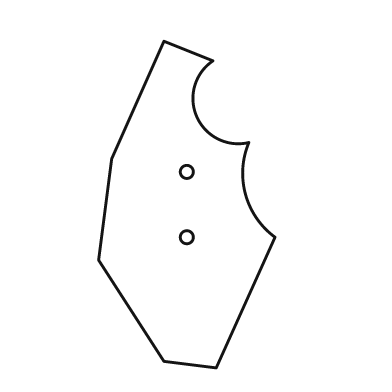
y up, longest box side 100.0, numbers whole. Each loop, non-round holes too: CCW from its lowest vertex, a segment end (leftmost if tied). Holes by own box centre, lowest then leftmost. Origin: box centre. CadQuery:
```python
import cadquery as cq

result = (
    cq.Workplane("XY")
    .moveTo(9.0, -50.0)
    .lineTo(27.0, -10.0)
    .threePointArc((18.0, 3.0), (19.0, 19.0))
    .threePointArc((3.0, 27.0), (8.0, 44.0))
    .lineTo(-7.0, 50.0)
    .lineTo(-23.0, 14.0)
    .lineTo(-27.0, -17.0)
    .lineTo(-7.0, -48.0)
    .close()
    .moveTo(0.0, -10.0)
    .circle(2.0)
    .moveTo(0.0, 10.0)
    .circle(2.0)
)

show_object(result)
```